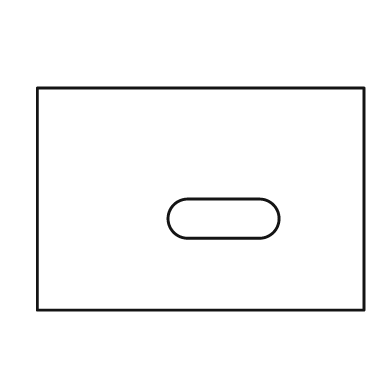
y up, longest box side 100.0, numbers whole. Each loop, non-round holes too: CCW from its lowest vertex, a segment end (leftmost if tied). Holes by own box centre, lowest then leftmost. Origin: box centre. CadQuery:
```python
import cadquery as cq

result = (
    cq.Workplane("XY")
    .moveTo(-50.0, -34.0)
    .lineTo(50.0, -34.0)
    .lineTo(50.0, 34.0)
    .lineTo(-50.0, 34.0)
    .close()
    .moveTo(-4.0, -12.0)
    .lineTo(18.0, -12.0)
    .threePointArc((24.0, -6.0), (18.0, 0.0))
    .lineTo(-4.0, 0.0)
    .threePointArc((-10.0, -6.0), (-4.0, -12.0))
    .close()
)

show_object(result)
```